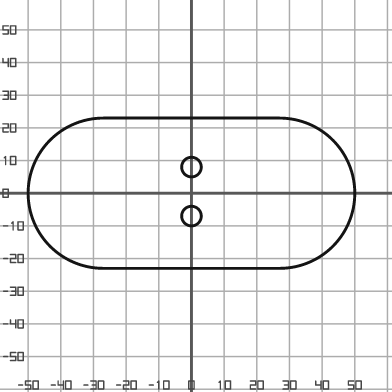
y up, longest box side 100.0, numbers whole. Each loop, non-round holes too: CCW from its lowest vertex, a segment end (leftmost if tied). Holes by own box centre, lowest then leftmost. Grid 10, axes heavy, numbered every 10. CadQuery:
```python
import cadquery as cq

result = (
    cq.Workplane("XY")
    .moveTo(-27.0, -23.0)
    .lineTo(27.0, -23.0)
    .threePointArc((50.0, 0.0), (27.0, 23.0))
    .lineTo(-27.0, 23.0)
    .threePointArc((-50.0, 0.0), (-27.0, -23.0))
    .close()
    .moveTo(0.0, -7.0)
    .circle(3.0)
    .moveTo(0.0, 8.0)
    .circle(3.0)
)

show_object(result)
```